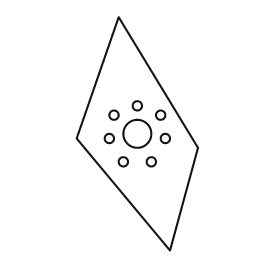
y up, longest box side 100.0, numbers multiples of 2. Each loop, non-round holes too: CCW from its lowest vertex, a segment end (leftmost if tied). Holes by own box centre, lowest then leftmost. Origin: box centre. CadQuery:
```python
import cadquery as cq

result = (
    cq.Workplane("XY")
    .moveTo(14.0, -50.0)
    .lineTo(26.0, -6.0)
    .lineTo(-8.0, 50.0)
    .lineTo(-26.0, -2.0)
    .close()
    .moveTo(-6.0, -12.0)
    .circle(2.0)
    .moveTo(6.0, -12.0)
    .circle(2.0)
    .moveTo(-12.0, -2.0)
    .circle(2.0)
    .moveTo(12.0, -2.0)
    .circle(2.0)
    .moveTo(0.0, 0.0)
    .circle(6.0)
    .moveTo(-10.0, 8.0)
    .circle(2.0)
    .moveTo(10.0, 8.0)
    .circle(2.0)
    .moveTo(0.0, 12.0)
    .circle(2.0)
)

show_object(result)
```